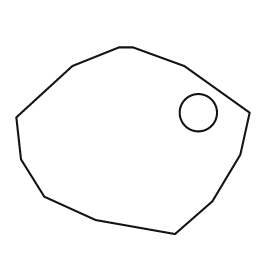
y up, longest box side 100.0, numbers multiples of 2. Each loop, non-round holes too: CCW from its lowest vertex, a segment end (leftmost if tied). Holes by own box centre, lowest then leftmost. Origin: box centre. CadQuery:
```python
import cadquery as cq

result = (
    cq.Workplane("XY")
    .moveTo(18.0, -40.0)
    .lineTo(34.0, -26.0)
    .lineTo(46.0, -6.0)
    .lineTo(50.0, 12.0)
    .lineTo(22.0, 32.0)
    .lineTo(0.0, 40.0)
    .lineTo(-6.0, 40.0)
    .lineTo(-26.0, 32.0)
    .lineTo(-50.0, 10.0)
    .lineTo(-48.0, -8.0)
    .lineTo(-38.0, -24.0)
    .lineTo(-16.0, -34.0)
    .close()
    .moveTo(28.0, 12.0)
    .circle(8.0)
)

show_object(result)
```